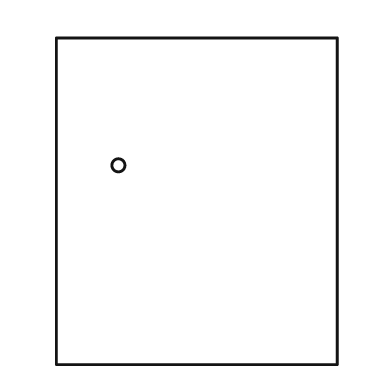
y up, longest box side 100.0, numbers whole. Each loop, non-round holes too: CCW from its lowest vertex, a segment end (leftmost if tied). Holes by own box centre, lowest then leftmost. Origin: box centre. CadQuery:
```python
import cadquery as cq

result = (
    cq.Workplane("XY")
    .moveTo(-43.0, -50.0)
    .lineTo(43.0, -50.0)
    .lineTo(43.0, 50.0)
    .lineTo(-43.0, 50.0)
    .close()
    .moveTo(-24.0, 11.0)
    .circle(2.0)
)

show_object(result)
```